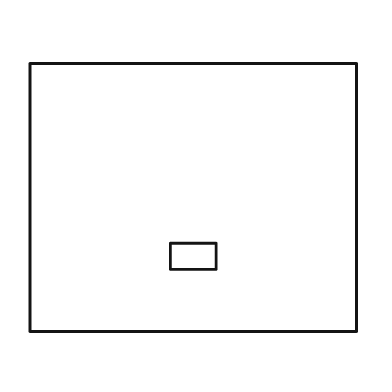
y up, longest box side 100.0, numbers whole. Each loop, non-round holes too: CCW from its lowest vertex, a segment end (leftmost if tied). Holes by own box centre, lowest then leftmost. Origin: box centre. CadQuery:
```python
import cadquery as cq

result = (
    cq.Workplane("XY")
    .moveTo(-50.0, -41.0)
    .lineTo(50.0, -41.0)
    .lineTo(50.0, 41.0)
    .lineTo(-50.0, 41.0)
    .close()
    .moveTo(-7.0, -22.0)
    .lineTo(7.0, -22.0)
    .lineTo(7.0, -14.0)
    .lineTo(-7.0, -14.0)
    .close()
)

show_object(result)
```